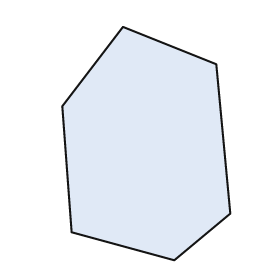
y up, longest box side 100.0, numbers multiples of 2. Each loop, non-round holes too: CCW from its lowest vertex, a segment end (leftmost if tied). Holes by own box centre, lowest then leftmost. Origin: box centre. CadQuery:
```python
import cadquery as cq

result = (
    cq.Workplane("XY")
    .moveTo(12.0, -50.0)
    .lineTo(36.0, -30.0)
    .lineTo(30.0, 34.0)
    .lineTo(-10.0, 50.0)
    .lineTo(-36.0, 16.0)
    .lineTo(-32.0, -38.0)
    .close()
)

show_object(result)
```